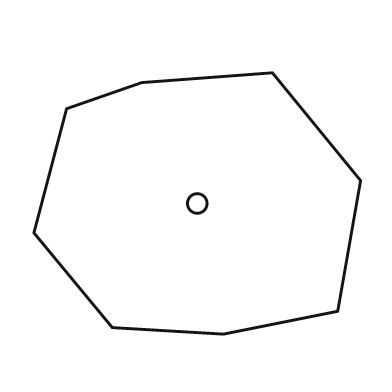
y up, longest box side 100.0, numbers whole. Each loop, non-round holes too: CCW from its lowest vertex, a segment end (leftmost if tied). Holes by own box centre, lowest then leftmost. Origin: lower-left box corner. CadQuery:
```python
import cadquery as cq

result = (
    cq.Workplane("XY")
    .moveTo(58.0, 0.0)
    .lineTo(93.0, 7.0)
    .lineTo(100.0, 47.0)
    .lineTo(73.0, 80.0)
    .lineTo(33.0, 77.0)
    .lineTo(10.0, 69.0)
    .lineTo(0.0, 31.0)
    .lineTo(24.0, 2.0)
    .close()
    .moveTo(50.0, 40.0)
    .circle(3.0)
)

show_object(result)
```